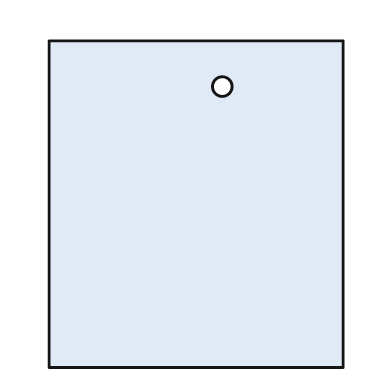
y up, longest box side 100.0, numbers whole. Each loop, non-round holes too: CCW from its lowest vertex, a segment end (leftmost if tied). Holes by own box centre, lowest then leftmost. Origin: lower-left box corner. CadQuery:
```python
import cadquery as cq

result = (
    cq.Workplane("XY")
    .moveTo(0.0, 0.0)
    .lineTo(90.0, 0.0)
    .lineTo(90.0, 100.0)
    .lineTo(0.0, 100.0)
    .close()
    .moveTo(53.0, 86.0)
    .circle(3.0)
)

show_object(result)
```